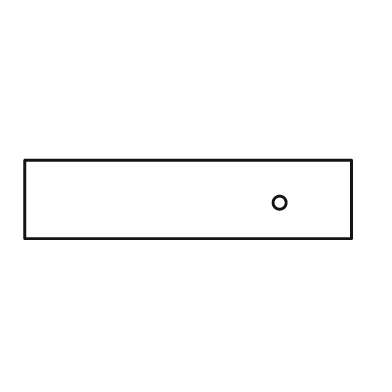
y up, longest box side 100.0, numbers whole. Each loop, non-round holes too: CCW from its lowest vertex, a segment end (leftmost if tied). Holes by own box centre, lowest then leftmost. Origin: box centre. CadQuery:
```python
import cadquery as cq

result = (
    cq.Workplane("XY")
    .moveTo(-50.0, -12.0)
    .lineTo(50.0, -12.0)
    .lineTo(50.0, 12.0)
    .lineTo(-50.0, 12.0)
    .close()
    .moveTo(28.0, -1.0)
    .circle(2.0)
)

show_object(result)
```